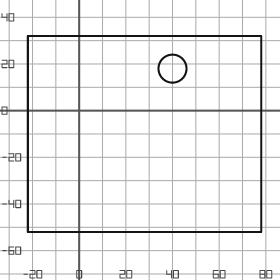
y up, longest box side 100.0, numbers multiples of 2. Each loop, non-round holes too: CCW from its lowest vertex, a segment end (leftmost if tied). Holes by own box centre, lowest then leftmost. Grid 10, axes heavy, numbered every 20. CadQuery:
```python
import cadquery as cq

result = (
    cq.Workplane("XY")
    .moveTo(-22.0, -52.0)
    .lineTo(78.0, -52.0)
    .lineTo(78.0, 32.0)
    .lineTo(-22.0, 32.0)
    .close()
    .moveTo(40.0, 18.0)
    .circle(6.0)
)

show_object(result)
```